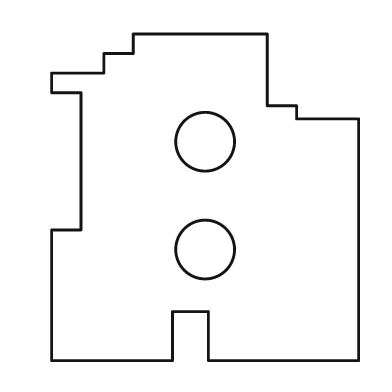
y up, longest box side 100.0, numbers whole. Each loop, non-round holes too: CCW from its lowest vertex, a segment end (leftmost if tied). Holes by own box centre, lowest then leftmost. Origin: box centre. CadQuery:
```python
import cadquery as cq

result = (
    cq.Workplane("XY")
    .moveTo(-47.0, -50.0)
    .lineTo(-10.0, -50.0)
    .lineTo(-10.0, -35.0)
    .lineTo(1.0, -35.0)
    .lineTo(1.0, -50.0)
    .lineTo(47.0, -50.0)
    .lineTo(47.0, 24.0)
    .lineTo(28.0, 24.0)
    .lineTo(28.0, 28.0)
    .lineTo(19.0, 28.0)
    .lineTo(19.0, 50.0)
    .lineTo(-22.0, 50.0)
    .lineTo(-22.0, 44.0)
    .lineTo(-31.0, 44.0)
    .lineTo(-31.0, 38.0)
    .lineTo(-47.0, 38.0)
    .lineTo(-47.0, 32.0)
    .lineTo(-38.0, 32.0)
    .lineTo(-38.0, -10.0)
    .lineTo(-47.0, -10.0)
    .close()
    .moveTo(0.0, -16.0)
    .circle(9.0)
    .moveTo(0.0, 17.0)
    .circle(9.0)
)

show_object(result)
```